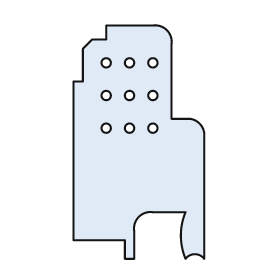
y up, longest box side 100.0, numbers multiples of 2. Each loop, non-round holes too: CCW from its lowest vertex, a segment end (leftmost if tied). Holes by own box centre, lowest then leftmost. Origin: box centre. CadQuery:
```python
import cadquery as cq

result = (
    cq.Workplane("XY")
    .moveTo(-6.0, -50.0)
    .lineTo(-2.0, -50.0)
    .lineTo(-2.0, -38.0)
    .threePointArc((0.0, -32.0), (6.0, -30.0))
    .lineTo(20.0, -30.0)
    .threePointArc((18.0, -40.0), (20.0, -50.0))
    .threePointArc((24.0, -48.0), (28.0, -50.0))
    .lineTo(28.0, 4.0)
    .threePointArc((26.0, 8.0), (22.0, 10.0))
    .lineTo(14.0, 10.0)
    .lineTo(14.0, 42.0)
    .threePointArc((12.0, 48.0), (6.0, 50.0))
    .lineTo(-14.0, 50.0)
    .lineTo(-14.0, 44.0)
    .lineTo(-20.0, 44.0)
    .lineTo(-24.0, 40.0)
    .lineTo(-24.0, 26.0)
    .lineTo(-28.0, 26.0)
    .lineTo(-28.0, -42.0)
    .lineTo(-6.0, -42.0)
    .close()
    .moveTo(-14.0, 6.0)
    .circle(2.0)
    .moveTo(-4.0, 6.0)
    .circle(2.0)
    .moveTo(6.0, 6.0)
    .circle(2.0)
    .moveTo(-14.0, 20.0)
    .circle(2.0)
    .moveTo(-4.0, 20.0)
    .circle(2.0)
    .moveTo(6.0, 20.0)
    .circle(2.0)
    .moveTo(-14.0, 34.0)
    .circle(2.0)
    .moveTo(-4.0, 34.0)
    .circle(2.0)
    .moveTo(6.0, 34.0)
    .circle(2.0)
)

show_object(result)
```